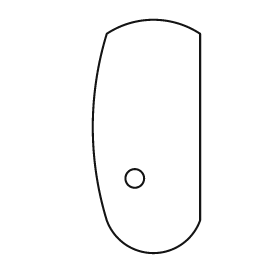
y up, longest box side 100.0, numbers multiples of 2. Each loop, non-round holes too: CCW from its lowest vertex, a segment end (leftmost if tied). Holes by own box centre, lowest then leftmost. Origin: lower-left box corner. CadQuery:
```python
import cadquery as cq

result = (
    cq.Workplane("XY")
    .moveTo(6.0, 14.0)
    .threePointArc((26.0, 0.0), (46.0, 14.0))
    .lineTo(46.0, 94.0)
    .threePointArc((26.0, 100.0), (6.0, 94.0))
    .threePointArc((0.0, 54.0), (6.0, 14.0))
    .close()
    .moveTo(18.0, 32.0)
    .circle(4.0)
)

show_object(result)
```